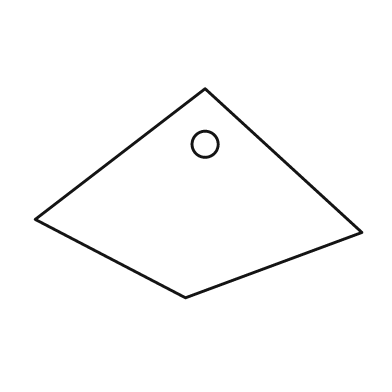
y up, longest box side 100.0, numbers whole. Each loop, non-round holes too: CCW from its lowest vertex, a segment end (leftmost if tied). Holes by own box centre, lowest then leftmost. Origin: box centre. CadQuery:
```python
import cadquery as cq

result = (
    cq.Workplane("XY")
    .moveTo(-4.0, -32.0)
    .lineTo(50.0, -12.0)
    .lineTo(2.0, 32.0)
    .lineTo(-50.0, -8.0)
    .close()
    .moveTo(2.0, 15.0)
    .circle(4.0)
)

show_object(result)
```